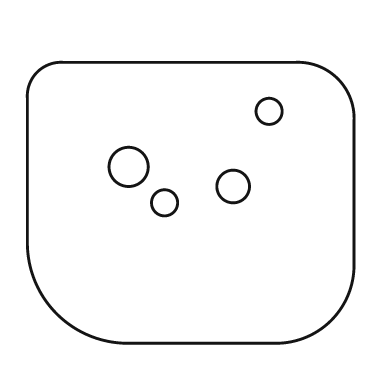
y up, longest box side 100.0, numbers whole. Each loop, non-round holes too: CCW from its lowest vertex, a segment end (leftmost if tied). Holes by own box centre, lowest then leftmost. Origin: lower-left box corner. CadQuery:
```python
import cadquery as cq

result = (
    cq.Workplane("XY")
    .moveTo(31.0, 0.0)
    .lineTo(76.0, 0.0)
    .threePointArc((93.0, 7.0), (100.0, 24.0))
    .lineTo(100.0, 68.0)
    .threePointArc((95.0, 81.0), (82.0, 86.0))
    .lineTo(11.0, 86.0)
    .threePointArc((3.0, 83.0), (0.0, 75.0))
    .lineTo(0.0, 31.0)
    .threePointArc((9.0, 9.0), (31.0, 0.0))
    .close()
    .moveTo(42.0, 43.0)
    .circle(4.0)
    .moveTo(63.0, 48.0)
    .circle(5.0)
    .moveTo(31.0, 54.0)
    .circle(6.0)
    .moveTo(74.0, 71.0)
    .circle(4.0)
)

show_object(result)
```